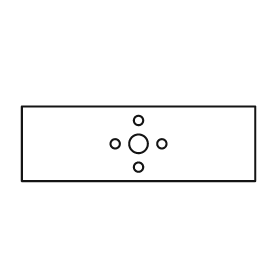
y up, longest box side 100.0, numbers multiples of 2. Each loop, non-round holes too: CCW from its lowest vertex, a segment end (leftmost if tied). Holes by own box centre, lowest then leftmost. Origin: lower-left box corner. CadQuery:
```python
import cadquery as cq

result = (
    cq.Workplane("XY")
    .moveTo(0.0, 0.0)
    .lineTo(100.0, 0.0)
    .lineTo(100.0, 32.0)
    .lineTo(0.0, 32.0)
    .close()
    .moveTo(50.0, 6.0)
    .circle(2.0)
    .moveTo(40.0, 16.0)
    .circle(2.0)
    .moveTo(50.0, 16.0)
    .circle(4.0)
    .moveTo(60.0, 16.0)
    .circle(2.0)
    .moveTo(50.0, 26.0)
    .circle(2.0)
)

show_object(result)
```